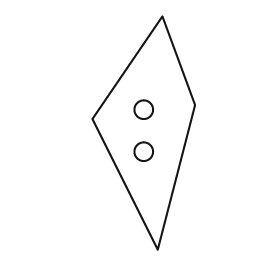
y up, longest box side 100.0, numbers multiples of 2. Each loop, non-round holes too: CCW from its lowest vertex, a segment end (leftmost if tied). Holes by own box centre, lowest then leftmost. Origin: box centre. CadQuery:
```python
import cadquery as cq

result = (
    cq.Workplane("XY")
    .moveTo(6.0, -50.0)
    .lineTo(22.0, 12.0)
    .lineTo(8.0, 50.0)
    .lineTo(-22.0, 6.0)
    .close()
    .moveTo(0.0, -8.0)
    .circle(4.0)
    .moveTo(0.0, 10.0)
    .circle(4.0)
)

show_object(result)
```